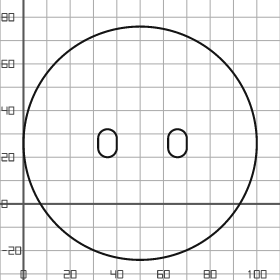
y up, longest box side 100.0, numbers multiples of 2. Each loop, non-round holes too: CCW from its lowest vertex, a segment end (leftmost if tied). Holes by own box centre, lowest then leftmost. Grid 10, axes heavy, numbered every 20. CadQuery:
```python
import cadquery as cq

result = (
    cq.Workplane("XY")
    .moveTo(50.0, 26.0)
    .circle(50.0)
    .moveTo(32.0, 24.0)
    .threePointArc((36.0, 20.0), (40.0, 24.0))
    .lineTo(40.0, 28.0)
    .threePointArc((36.0, 32.0), (32.0, 28.0))
    .close()
    .moveTo(62.0, 24.0)
    .threePointArc((66.0, 20.0), (70.0, 24.0))
    .lineTo(70.0, 28.0)
    .threePointArc((66.0, 32.0), (62.0, 28.0))
    .close()
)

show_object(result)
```